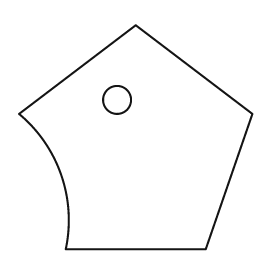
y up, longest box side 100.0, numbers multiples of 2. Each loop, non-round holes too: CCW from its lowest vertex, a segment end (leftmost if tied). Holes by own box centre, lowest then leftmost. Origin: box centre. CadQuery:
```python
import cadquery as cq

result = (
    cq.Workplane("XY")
    .moveTo(-30.0, -48.0)
    .lineTo(30.0, -48.0)
    .lineTo(50.0, 10.0)
    .lineTo(0.0, 48.0)
    .lineTo(-50.0, 10.0)
    .threePointArc((-32.0, -16.0), (-30.0, -48.0))
    .close()
    .moveTo(-8.0, 16.0)
    .circle(6.0)
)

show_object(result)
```